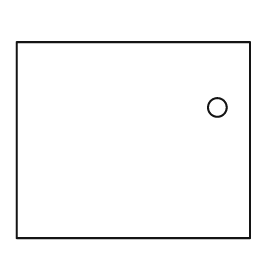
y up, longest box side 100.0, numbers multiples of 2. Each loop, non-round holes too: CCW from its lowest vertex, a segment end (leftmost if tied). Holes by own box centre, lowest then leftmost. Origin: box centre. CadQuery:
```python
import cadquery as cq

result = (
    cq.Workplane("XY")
    .moveTo(-50.0, -42.0)
    .lineTo(50.0, -42.0)
    .lineTo(50.0, 42.0)
    .lineTo(-50.0, 42.0)
    .close()
    .moveTo(36.0, 14.0)
    .circle(4.0)
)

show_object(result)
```